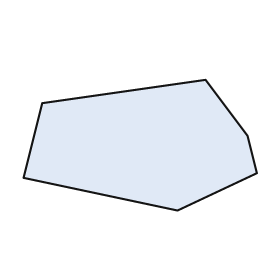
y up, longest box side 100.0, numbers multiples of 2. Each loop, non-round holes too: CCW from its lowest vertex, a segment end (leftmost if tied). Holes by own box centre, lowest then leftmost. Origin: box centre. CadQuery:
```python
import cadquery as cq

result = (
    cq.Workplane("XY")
    .moveTo(16.0, -28.0)
    .lineTo(50.0, -12.0)
    .lineTo(46.0, 4.0)
    .lineTo(28.0, 28.0)
    .lineTo(-42.0, 18.0)
    .lineTo(-50.0, -14.0)
    .close()
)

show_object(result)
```